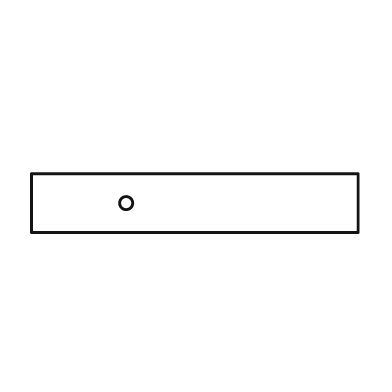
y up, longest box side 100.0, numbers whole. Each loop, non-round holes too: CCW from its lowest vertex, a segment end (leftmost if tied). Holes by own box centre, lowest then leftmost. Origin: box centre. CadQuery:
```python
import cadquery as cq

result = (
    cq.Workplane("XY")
    .moveTo(-50.0, -9.0)
    .lineTo(50.0, -9.0)
    .lineTo(50.0, 9.0)
    .lineTo(-50.0, 9.0)
    .close()
    .moveTo(-21.0, 0.0)
    .circle(2.0)
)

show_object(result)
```